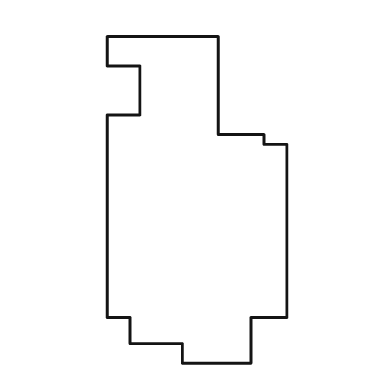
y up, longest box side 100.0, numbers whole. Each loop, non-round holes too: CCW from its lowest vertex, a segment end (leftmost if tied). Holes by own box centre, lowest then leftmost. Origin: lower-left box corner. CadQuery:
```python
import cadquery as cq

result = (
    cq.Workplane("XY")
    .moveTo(23.0, 0.0)
    .lineTo(44.0, 0.0)
    .lineTo(44.0, 14.0)
    .lineTo(55.0, 14.0)
    .lineTo(55.0, 67.0)
    .lineTo(48.0, 67.0)
    .lineTo(48.0, 70.0)
    .lineTo(34.0, 70.0)
    .lineTo(34.0, 100.0)
    .lineTo(0.0, 100.0)
    .lineTo(0.0, 91.0)
    .lineTo(10.0, 91.0)
    .lineTo(10.0, 76.0)
    .lineTo(0.0, 76.0)
    .lineTo(0.0, 14.0)
    .lineTo(7.0, 14.0)
    .lineTo(7.0, 6.0)
    .lineTo(23.0, 6.0)
    .close()
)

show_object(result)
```